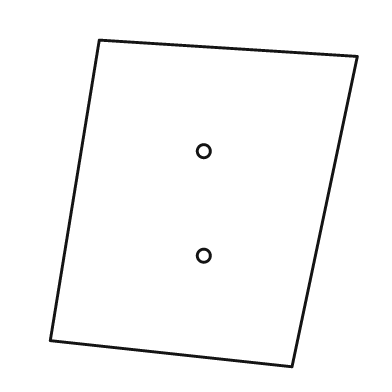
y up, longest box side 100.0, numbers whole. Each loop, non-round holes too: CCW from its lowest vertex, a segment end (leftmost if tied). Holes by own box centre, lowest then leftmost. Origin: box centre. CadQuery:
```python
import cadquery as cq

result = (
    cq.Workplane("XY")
    .moveTo(27.0, -50.0)
    .lineTo(47.0, 45.0)
    .lineTo(-32.0, 50.0)
    .lineTo(-47.0, -42.0)
    .close()
    .moveTo(0.0, -16.0)
    .circle(2.0)
    .moveTo(0.0, 16.0)
    .circle(2.0)
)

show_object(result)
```